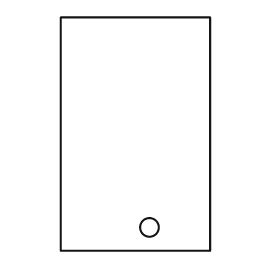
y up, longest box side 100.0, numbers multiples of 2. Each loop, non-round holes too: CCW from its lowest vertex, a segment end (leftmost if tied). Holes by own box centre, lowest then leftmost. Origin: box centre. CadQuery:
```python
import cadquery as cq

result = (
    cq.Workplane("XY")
    .moveTo(-32.0, -50.0)
    .lineTo(32.0, -50.0)
    .lineTo(32.0, 50.0)
    .lineTo(-32.0, 50.0)
    .close()
    .moveTo(6.0, -40.0)
    .circle(4.0)
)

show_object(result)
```